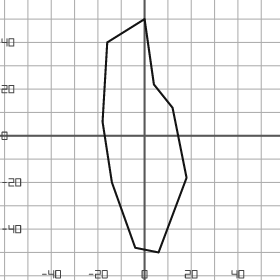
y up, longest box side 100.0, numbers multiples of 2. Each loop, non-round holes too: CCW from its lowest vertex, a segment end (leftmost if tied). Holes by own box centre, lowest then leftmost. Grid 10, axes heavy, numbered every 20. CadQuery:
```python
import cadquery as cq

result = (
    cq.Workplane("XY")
    .moveTo(6.0, -50.0)
    .lineTo(18.0, -18.0)
    .lineTo(12.0, 12.0)
    .lineTo(4.0, 22.0)
    .lineTo(0.0, 50.0)
    .lineTo(-16.0, 40.0)
    .lineTo(-18.0, 6.0)
    .lineTo(-14.0, -20.0)
    .lineTo(-4.0, -48.0)
    .close()
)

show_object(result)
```